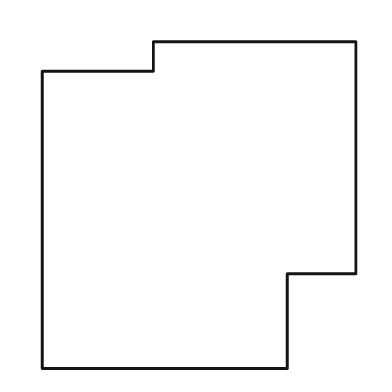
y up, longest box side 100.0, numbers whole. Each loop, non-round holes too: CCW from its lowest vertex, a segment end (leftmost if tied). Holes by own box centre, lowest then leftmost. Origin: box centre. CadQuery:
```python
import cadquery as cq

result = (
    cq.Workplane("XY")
    .moveTo(-48.0, -50.0)
    .lineTo(27.0, -50.0)
    .lineTo(27.0, -21.0)
    .lineTo(48.0, -21.0)
    .lineTo(48.0, 50.0)
    .lineTo(-14.0, 50.0)
    .lineTo(-14.0, 41.0)
    .lineTo(-48.0, 41.0)
    .close()
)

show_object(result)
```